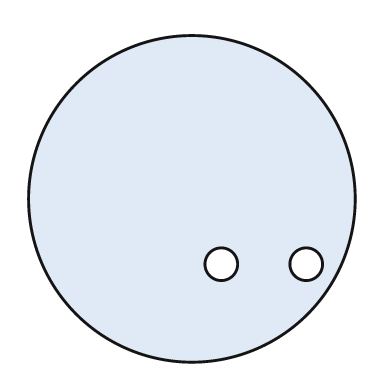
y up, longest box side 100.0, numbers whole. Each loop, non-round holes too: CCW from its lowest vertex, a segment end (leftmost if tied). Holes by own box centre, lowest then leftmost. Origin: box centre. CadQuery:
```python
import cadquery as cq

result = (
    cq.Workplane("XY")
    .moveTo(0.0, 0.0)
    .circle(50.0)
    .moveTo(9.0, -20.0)
    .circle(5.0)
    .moveTo(35.0, -20.0)
    .circle(5.0)
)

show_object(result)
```